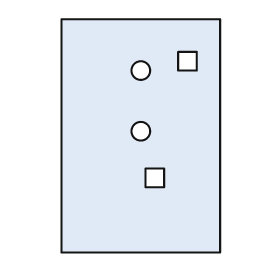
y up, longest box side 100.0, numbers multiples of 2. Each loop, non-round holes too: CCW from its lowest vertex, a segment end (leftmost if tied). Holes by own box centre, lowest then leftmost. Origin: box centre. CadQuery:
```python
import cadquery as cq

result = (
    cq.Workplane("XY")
    .moveTo(-34.0, -50.0)
    .lineTo(34.0, -50.0)
    .lineTo(34.0, 50.0)
    .lineTo(-34.0, 50.0)
    .close()
    .moveTo(2.0, -22.0)
    .lineTo(10.0, -22.0)
    .lineTo(10.0, -14.0)
    .lineTo(2.0, -14.0)
    .close()
    .moveTo(0.0, 2.0)
    .circle(4.0)
    .moveTo(0.0, 28.0)
    .circle(4.0)
    .moveTo(16.0, 28.0)
    .lineTo(24.0, 28.0)
    .lineTo(24.0, 36.0)
    .lineTo(16.0, 36.0)
    .close()
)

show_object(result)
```